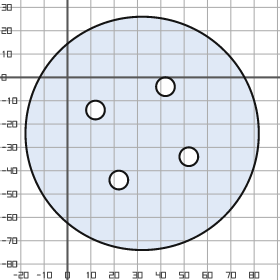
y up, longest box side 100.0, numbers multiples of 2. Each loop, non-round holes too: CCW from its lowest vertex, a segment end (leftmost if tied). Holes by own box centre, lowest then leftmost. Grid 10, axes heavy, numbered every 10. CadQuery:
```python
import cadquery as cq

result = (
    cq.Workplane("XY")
    .moveTo(32.0, -24.0)
    .circle(50.0)
    .moveTo(22.0, -44.0)
    .circle(4.0)
    .moveTo(52.0, -34.0)
    .circle(4.0)
    .moveTo(12.0, -14.0)
    .circle(4.0)
    .moveTo(42.0, -4.0)
    .circle(4.0)
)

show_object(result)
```